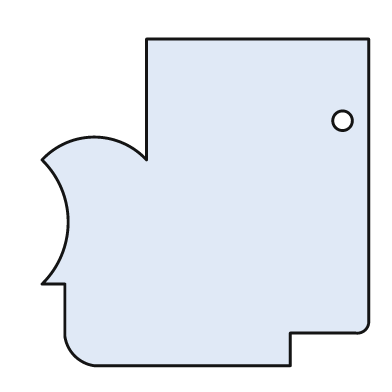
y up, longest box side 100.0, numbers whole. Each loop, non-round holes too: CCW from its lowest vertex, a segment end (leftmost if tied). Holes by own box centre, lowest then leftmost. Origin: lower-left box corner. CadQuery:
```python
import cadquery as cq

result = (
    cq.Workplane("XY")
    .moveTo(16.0, 0.0)
    .lineTo(76.0, 0.0)
    .lineTo(76.0, 10.0)
    .lineTo(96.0, 10.0)
    .threePointArc((99.0, 11.0), (100.0, 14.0))
    .lineTo(100.0, 100.0)
    .lineTo(32.0, 100.0)
    .lineTo(32.0, 63.0)
    .threePointArc((16.0, 70.0), (0.0, 63.0))
    .threePointArc((8.0, 44.0), (0.0, 25.0))
    .lineTo(7.0, 25.0)
    .lineTo(7.0, 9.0)
    .threePointArc((10.0, 3.0), (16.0, 0.0))
    .close()
    .moveTo(92.0, 75.0)
    .circle(3.0)
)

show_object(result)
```